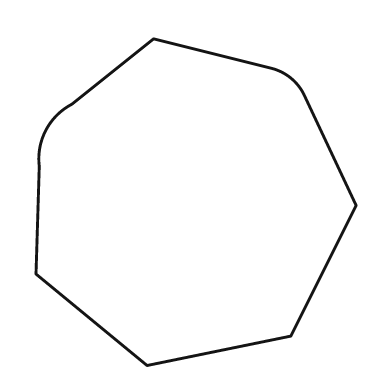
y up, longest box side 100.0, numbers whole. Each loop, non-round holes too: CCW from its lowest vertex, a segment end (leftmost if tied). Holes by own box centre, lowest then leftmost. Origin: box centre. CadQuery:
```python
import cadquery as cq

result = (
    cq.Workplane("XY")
    .moveTo(-15.0, -50.0)
    .lineTo(29.0, -41.0)
    .lineTo(49.0, -1.0)
    .lineTo(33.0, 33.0)
    .threePointArc((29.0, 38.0), (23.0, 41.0))
    .lineTo(-13.0, 50.0)
    .lineTo(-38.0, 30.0)
    .threePointArc((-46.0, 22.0), (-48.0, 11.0))
    .lineTo(-49.0, -22.0)
    .close()
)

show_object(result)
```